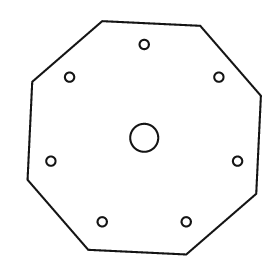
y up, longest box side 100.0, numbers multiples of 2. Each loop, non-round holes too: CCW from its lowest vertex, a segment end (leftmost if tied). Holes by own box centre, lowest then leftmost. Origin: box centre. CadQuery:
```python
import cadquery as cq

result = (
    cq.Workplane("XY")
    .moveTo(18.0, -50.0)
    .lineTo(48.0, -24.0)
    .lineTo(50.0, 18.0)
    .lineTo(24.0, 48.0)
    .lineTo(-18.0, 50.0)
    .lineTo(-48.0, 24.0)
    .lineTo(-50.0, -18.0)
    .lineTo(-24.0, -48.0)
    .close()
    .moveTo(-18.0, -36.0)
    .circle(2.0)
    .moveTo(18.0, -36.0)
    .circle(2.0)
    .moveTo(-40.0, -10.0)
    .circle(2.0)
    .moveTo(40.0, -10.0)
    .circle(2.0)
    .moveTo(0.0, 0.0)
    .circle(6.0)
    .moveTo(-32.0, 26.0)
    .circle(2.0)
    .moveTo(32.0, 26.0)
    .circle(2.0)
    .moveTo(0.0, 40.0)
    .circle(2.0)
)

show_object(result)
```